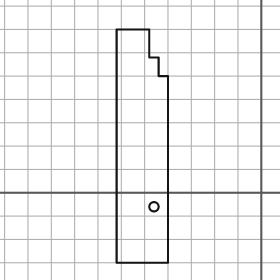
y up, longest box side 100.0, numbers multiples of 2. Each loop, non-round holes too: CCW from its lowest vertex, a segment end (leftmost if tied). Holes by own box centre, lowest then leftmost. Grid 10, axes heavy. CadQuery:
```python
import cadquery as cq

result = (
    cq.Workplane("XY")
    .moveTo(-62.0, -30.0)
    .lineTo(-40.0, -30.0)
    .lineTo(-40.0, 50.0)
    .lineTo(-44.0, 50.0)
    .lineTo(-44.0, 58.0)
    .lineTo(-48.0, 58.0)
    .lineTo(-48.0, 70.0)
    .lineTo(-62.0, 70.0)
    .close()
    .moveTo(-46.0, -6.0)
    .circle(2.0)
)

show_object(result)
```